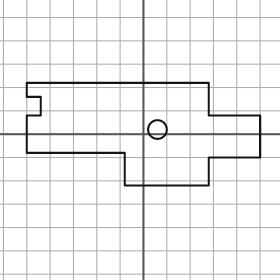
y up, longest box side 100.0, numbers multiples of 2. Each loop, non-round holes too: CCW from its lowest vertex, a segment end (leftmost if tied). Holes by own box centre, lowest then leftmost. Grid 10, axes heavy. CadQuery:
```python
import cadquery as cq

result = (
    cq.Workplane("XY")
    .moveTo(-8.0, -22.0)
    .lineTo(28.0, -22.0)
    .lineTo(28.0, -10.0)
    .lineTo(50.0, -10.0)
    .lineTo(50.0, 8.0)
    .lineTo(28.0, 8.0)
    .lineTo(28.0, 22.0)
    .lineTo(-50.0, 22.0)
    .lineTo(-50.0, 16.0)
    .lineTo(-44.0, 16.0)
    .lineTo(-44.0, 8.0)
    .lineTo(-50.0, 8.0)
    .lineTo(-50.0, -8.0)
    .lineTo(-8.0, -8.0)
    .close()
    .moveTo(6.0, 2.0)
    .circle(4.0)
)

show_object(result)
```